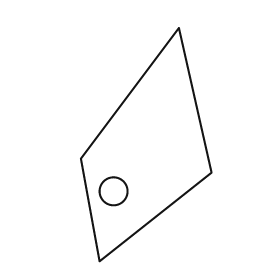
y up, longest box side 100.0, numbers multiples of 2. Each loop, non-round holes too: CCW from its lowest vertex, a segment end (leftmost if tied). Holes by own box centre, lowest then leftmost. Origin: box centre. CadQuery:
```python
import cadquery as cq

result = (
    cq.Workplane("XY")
    .moveTo(-20.0, -50.0)
    .lineTo(28.0, -12.0)
    .lineTo(14.0, 50.0)
    .lineTo(-28.0, -6.0)
    .close()
    .moveTo(-14.0, -20.0)
    .circle(6.0)
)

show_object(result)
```